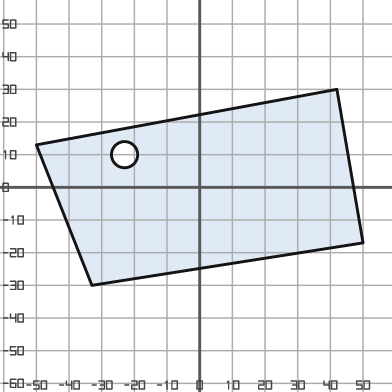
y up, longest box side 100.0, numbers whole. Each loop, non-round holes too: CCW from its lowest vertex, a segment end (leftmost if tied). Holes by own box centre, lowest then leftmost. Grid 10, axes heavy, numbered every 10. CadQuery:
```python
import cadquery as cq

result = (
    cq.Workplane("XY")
    .moveTo(-33.0, -30.0)
    .lineTo(50.0, -17.0)
    .lineTo(42.0, 30.0)
    .lineTo(-50.0, 13.0)
    .close()
    .moveTo(-23.0, 10.0)
    .circle(4.0)
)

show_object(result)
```